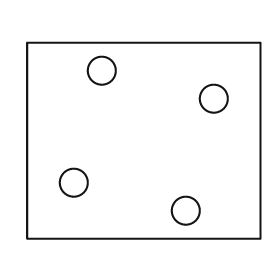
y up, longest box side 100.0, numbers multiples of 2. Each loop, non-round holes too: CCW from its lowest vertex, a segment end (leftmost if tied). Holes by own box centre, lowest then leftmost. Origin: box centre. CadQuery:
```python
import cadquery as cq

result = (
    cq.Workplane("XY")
    .moveTo(-50.0, -42.0)
    .lineTo(50.0, -42.0)
    .lineTo(50.0, 42.0)
    .lineTo(-50.0, 42.0)
    .close()
    .moveTo(18.0, -30.0)
    .circle(6.0)
    .moveTo(-30.0, -18.0)
    .circle(6.0)
    .moveTo(30.0, 18.0)
    .circle(6.0)
    .moveTo(-18.0, 30.0)
    .circle(6.0)
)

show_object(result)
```